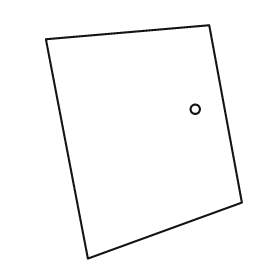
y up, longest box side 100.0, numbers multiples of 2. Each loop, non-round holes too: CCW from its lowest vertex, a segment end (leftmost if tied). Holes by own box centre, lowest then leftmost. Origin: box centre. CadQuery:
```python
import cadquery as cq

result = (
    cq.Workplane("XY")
    .moveTo(-24.0, -50.0)
    .lineTo(42.0, -26.0)
    .lineTo(28.0, 50.0)
    .lineTo(-42.0, 44.0)
    .close()
    .moveTo(22.0, 14.0)
    .circle(2.0)
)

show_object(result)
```